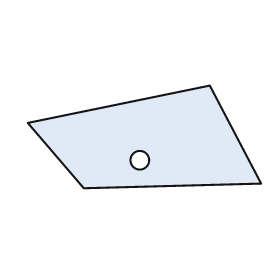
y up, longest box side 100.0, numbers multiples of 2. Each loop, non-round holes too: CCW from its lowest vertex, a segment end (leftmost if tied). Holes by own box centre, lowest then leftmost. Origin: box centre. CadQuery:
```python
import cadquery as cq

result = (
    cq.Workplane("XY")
    .moveTo(-26.0, -22.0)
    .lineTo(50.0, -20.0)
    .lineTo(28.0, 22.0)
    .lineTo(-50.0, 6.0)
    .close()
    .moveTo(-2.0, -10.0)
    .circle(4.0)
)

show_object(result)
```